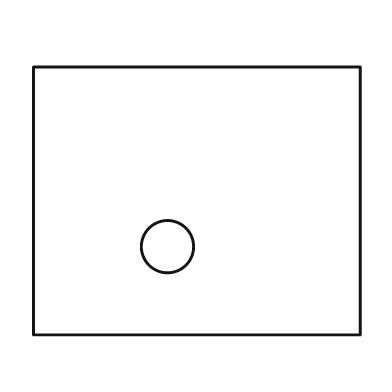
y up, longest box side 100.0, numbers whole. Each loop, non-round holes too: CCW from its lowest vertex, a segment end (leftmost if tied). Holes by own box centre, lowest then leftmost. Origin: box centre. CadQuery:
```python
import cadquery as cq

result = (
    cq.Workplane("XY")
    .moveTo(-50.0, -41.0)
    .lineTo(50.0, -41.0)
    .lineTo(50.0, 41.0)
    .lineTo(-50.0, 41.0)
    .close()
    .moveTo(-9.0, -14.0)
    .circle(8.0)
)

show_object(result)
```